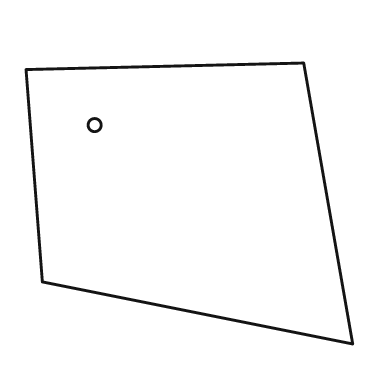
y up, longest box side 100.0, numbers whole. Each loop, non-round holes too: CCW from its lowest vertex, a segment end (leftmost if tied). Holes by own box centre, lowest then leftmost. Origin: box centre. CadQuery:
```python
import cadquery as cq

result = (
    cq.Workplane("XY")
    .moveTo(50.0, -43.0)
    .lineTo(35.0, 43.0)
    .lineTo(-50.0, 41.0)
    .lineTo(-45.0, -24.0)
    .close()
    .moveTo(-29.0, 24.0)
    .circle(2.0)
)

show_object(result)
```